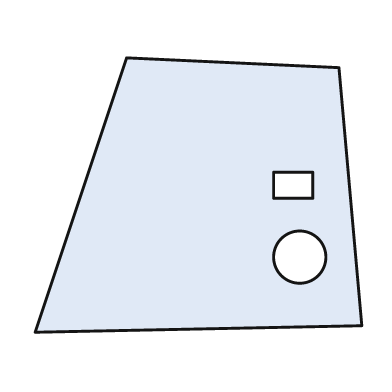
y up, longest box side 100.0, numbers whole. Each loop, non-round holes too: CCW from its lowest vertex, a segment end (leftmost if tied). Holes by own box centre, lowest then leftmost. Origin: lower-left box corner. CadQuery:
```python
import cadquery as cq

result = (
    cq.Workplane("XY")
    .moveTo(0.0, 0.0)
    .lineTo(100.0, 2.0)
    .lineTo(93.0, 81.0)
    .lineTo(28.0, 84.0)
    .close()
    .moveTo(81.0, 23.0)
    .circle(8.0)
    .moveTo(73.0, 41.0)
    .lineTo(85.0, 41.0)
    .lineTo(85.0, 49.0)
    .lineTo(73.0, 49.0)
    .close()
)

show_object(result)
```